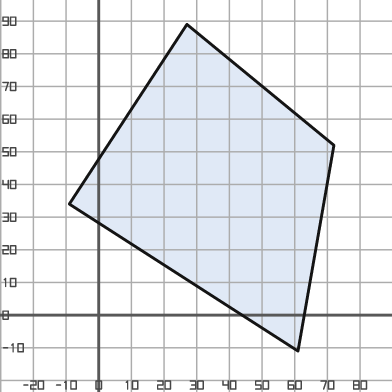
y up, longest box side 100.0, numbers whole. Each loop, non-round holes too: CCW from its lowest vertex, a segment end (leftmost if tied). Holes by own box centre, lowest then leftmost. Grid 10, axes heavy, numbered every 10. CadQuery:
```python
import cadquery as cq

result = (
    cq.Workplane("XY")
    .moveTo(61.0, -11.0)
    .lineTo(72.0, 52.0)
    .lineTo(27.0, 89.0)
    .lineTo(-9.0, 34.0)
    .close()
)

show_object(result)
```